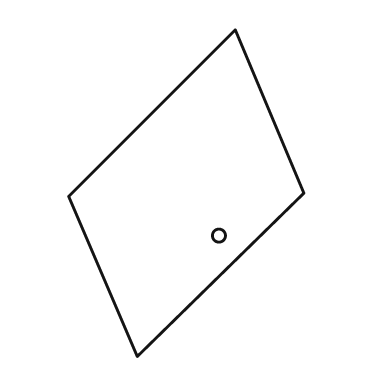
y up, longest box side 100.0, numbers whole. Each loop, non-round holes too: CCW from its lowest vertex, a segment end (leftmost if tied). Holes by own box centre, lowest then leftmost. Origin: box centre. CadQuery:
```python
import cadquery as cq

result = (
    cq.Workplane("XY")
    .moveTo(-15.0, -50.0)
    .lineTo(36.0, 0.0)
    .lineTo(15.0, 50.0)
    .lineTo(-36.0, -1.0)
    .close()
    .moveTo(10.0, -13.0)
    .circle(2.0)
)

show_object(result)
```